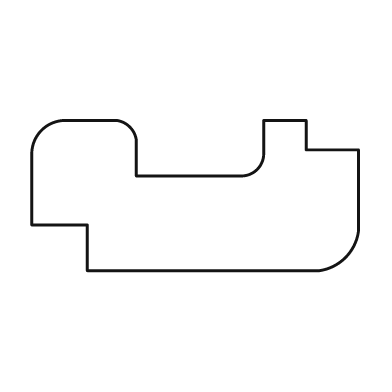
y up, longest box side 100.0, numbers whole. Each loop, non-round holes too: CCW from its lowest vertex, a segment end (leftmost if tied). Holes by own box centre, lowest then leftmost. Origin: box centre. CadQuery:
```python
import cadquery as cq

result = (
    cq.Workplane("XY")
    .moveTo(-33.0, -23.0)
    .lineTo(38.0, -23.0)
    .threePointArc((46.0, -19.0), (50.0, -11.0))
    .lineTo(50.0, 14.0)
    .lineTo(34.0, 14.0)
    .lineTo(34.0, 23.0)
    .lineTo(21.0, 23.0)
    .lineTo(21.0, 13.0)
    .threePointArc((19.0, 8.0), (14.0, 6.0))
    .lineTo(-18.0, 6.0)
    .lineTo(-18.0, 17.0)
    .threePointArc((-20.0, 21.0), (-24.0, 23.0))
    .lineTo(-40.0, 23.0)
    .threePointArc((-47.0, 20.0), (-50.0, 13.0))
    .lineTo(-50.0, -9.0)
    .lineTo(-33.0, -9.0)
    .close()
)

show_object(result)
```